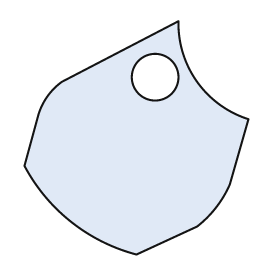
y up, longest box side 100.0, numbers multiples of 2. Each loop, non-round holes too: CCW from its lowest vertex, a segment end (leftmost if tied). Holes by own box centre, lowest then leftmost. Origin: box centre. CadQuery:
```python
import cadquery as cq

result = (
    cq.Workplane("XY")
    .moveTo(0.0, -50.0)
    .lineTo(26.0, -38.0)
    .threePointArc((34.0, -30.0), (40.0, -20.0))
    .lineTo(48.0, 8.0)
    .threePointArc((26.0, 24.0), (18.0, 50.0))
    .lineTo(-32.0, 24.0)
    .threePointArc((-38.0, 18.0), (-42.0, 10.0))
    .lineTo(-48.0, -12.0)
    .threePointArc((-28.0, -36.0), (0.0, -50.0))
    .close()
    .moveTo(8.0, 26.0)
    .circle(10.0)
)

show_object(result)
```